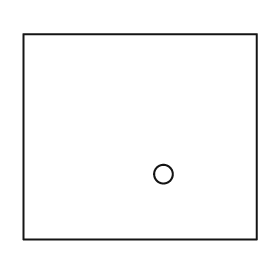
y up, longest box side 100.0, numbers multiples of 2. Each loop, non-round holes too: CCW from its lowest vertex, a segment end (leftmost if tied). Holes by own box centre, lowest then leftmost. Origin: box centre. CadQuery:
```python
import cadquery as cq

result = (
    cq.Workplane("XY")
    .moveTo(-50.0, -44.0)
    .lineTo(50.0, -44.0)
    .lineTo(50.0, 44.0)
    .lineTo(-50.0, 44.0)
    .close()
    .moveTo(10.0, -16.0)
    .circle(4.0)
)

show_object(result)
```